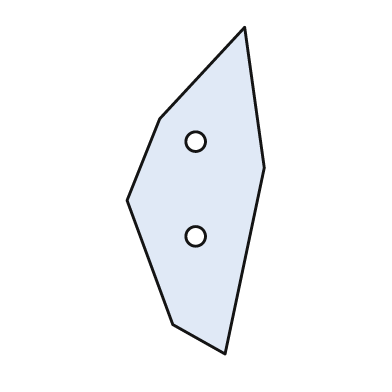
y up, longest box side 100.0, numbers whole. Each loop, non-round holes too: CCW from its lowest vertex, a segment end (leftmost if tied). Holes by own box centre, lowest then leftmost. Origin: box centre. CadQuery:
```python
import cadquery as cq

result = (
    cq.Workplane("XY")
    .moveTo(9.0, -50.0)
    .lineTo(21.0, 7.0)
    .lineTo(15.0, 50.0)
    .lineTo(-11.0, 22.0)
    .lineTo(-21.0, -3.0)
    .lineTo(-7.0, -41.0)
    .close()
    .moveTo(0.0, -14.0)
    .circle(3.0)
    .moveTo(0.0, 15.0)
    .circle(3.0)
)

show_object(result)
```